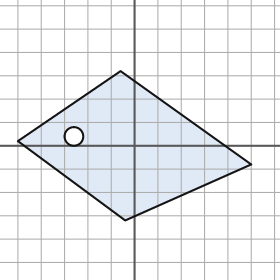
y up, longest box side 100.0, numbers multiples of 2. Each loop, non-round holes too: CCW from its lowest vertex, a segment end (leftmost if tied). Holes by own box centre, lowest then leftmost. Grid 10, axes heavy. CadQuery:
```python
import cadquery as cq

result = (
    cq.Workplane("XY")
    .moveTo(-4.0, -32.0)
    .lineTo(50.0, -8.0)
    .lineTo(-6.0, 32.0)
    .lineTo(-50.0, 2.0)
    .close()
    .moveTo(-26.0, 4.0)
    .circle(4.0)
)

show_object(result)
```